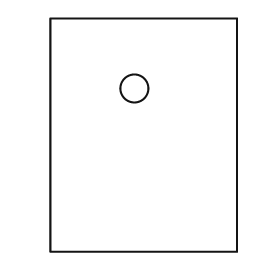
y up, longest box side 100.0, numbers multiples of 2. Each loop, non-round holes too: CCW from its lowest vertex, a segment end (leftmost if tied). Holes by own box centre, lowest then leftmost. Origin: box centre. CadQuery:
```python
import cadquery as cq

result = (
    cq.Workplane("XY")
    .moveTo(-40.0, -50.0)
    .lineTo(40.0, -50.0)
    .lineTo(40.0, 50.0)
    .lineTo(-40.0, 50.0)
    .close()
    .moveTo(-4.0, 20.0)
    .circle(6.0)
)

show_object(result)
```